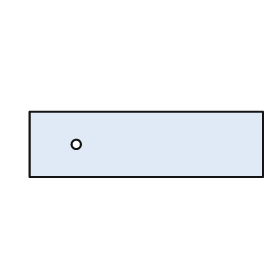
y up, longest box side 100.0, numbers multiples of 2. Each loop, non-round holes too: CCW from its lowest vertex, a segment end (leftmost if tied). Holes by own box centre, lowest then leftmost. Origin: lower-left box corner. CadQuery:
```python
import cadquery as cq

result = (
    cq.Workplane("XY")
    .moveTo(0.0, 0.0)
    .lineTo(100.0, 0.0)
    .lineTo(100.0, 28.0)
    .lineTo(0.0, 28.0)
    .close()
    .moveTo(20.0, 14.0)
    .circle(2.0)
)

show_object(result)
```